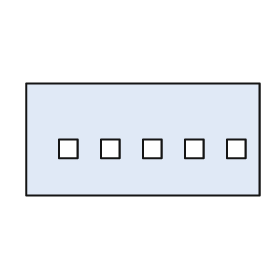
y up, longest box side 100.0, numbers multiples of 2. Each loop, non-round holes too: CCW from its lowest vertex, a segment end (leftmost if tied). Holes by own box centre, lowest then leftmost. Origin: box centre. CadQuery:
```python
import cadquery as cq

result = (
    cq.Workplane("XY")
    .moveTo(-50.0, -24.0)
    .lineTo(50.0, -24.0)
    .lineTo(50.0, 24.0)
    .lineTo(-50.0, 24.0)
    .close()
    .moveTo(-36.0, -8.0)
    .lineTo(-28.0, -8.0)
    .lineTo(-28.0, 0.0)
    .lineTo(-36.0, 0.0)
    .close()
    .moveTo(-18.0, -8.0)
    .lineTo(-10.0, -8.0)
    .lineTo(-10.0, 0.0)
    .lineTo(-18.0, 0.0)
    .close()
    .moveTo(0.0, -8.0)
    .lineTo(8.0, -8.0)
    .lineTo(8.0, 0.0)
    .lineTo(0.0, 0.0)
    .close()
    .moveTo(18.0, -8.0)
    .lineTo(26.0, -8.0)
    .lineTo(26.0, 0.0)
    .lineTo(18.0, 0.0)
    .close()
    .moveTo(36.0, -8.0)
    .lineTo(44.0, -8.0)
    .lineTo(44.0, 0.0)
    .lineTo(36.0, 0.0)
    .close()
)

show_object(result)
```